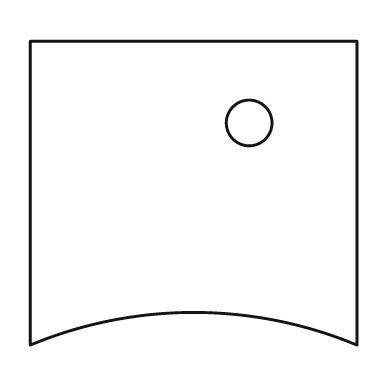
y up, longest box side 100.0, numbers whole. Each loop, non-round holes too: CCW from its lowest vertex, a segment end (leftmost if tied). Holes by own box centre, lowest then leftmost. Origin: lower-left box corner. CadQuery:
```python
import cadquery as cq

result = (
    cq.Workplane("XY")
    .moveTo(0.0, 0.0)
    .threePointArc((50.0, 10.0), (100.0, 0.0))
    .lineTo(100.0, 93.0)
    .lineTo(0.0, 93.0)
    .close()
    .moveTo(67.0, 68.0)
    .circle(7.0)
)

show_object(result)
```